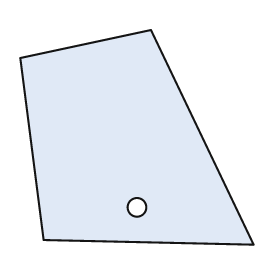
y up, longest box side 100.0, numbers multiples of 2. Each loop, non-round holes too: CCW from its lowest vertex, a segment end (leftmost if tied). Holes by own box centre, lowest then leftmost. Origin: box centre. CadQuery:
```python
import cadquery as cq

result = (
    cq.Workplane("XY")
    .moveTo(50.0, -46.0)
    .lineTo(6.0, 46.0)
    .lineTo(-50.0, 34.0)
    .lineTo(-40.0, -44.0)
    .close()
    .moveTo(0.0, -30.0)
    .circle(4.0)
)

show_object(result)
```